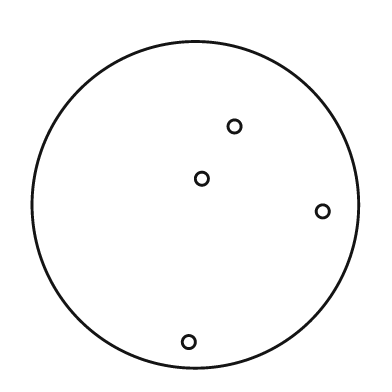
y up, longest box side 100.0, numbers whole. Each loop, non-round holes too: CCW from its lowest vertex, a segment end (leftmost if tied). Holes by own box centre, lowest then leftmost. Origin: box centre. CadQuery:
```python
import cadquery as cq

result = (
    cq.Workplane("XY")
    .moveTo(0.0, 0.0)
    .circle(50.0)
    .moveTo(-2.0, -42.0)
    .circle(2.0)
    .moveTo(39.0, -2.0)
    .circle(2.0)
    .moveTo(2.0, 8.0)
    .circle(2.0)
    .moveTo(12.0, 24.0)
    .circle(2.0)
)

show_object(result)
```